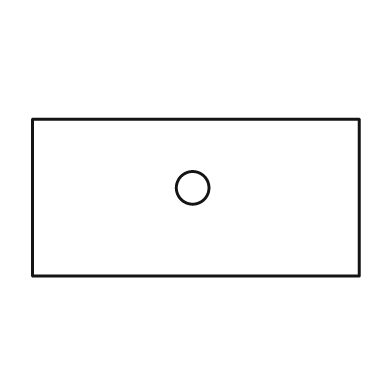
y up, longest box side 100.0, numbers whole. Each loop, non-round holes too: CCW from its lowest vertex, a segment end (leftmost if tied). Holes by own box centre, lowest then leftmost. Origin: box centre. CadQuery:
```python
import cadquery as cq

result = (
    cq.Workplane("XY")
    .moveTo(-50.0, -24.0)
    .lineTo(50.0, -24.0)
    .lineTo(50.0, 24.0)
    .lineTo(-50.0, 24.0)
    .close()
    .moveTo(-1.0, 3.0)
    .circle(5.0)
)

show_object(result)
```